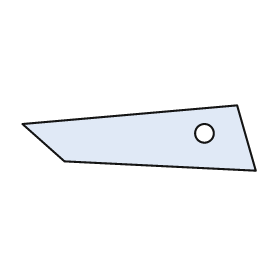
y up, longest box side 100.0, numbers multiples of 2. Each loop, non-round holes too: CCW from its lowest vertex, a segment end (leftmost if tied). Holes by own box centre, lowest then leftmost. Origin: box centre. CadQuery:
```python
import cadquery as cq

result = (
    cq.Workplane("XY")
    .moveTo(50.0, -14.0)
    .lineTo(42.0, 14.0)
    .lineTo(-50.0, 6.0)
    .lineTo(-32.0, -10.0)
    .close()
    .moveTo(28.0, 2.0)
    .circle(4.0)
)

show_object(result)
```